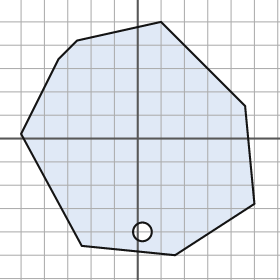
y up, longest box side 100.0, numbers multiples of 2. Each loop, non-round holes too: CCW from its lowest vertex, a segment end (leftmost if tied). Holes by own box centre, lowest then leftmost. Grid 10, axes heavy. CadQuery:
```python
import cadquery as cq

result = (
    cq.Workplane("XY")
    .moveTo(16.0, -50.0)
    .lineTo(50.0, -28.0)
    .lineTo(46.0, 14.0)
    .lineTo(10.0, 50.0)
    .lineTo(-26.0, 42.0)
    .lineTo(-34.0, 34.0)
    .lineTo(-50.0, 2.0)
    .lineTo(-24.0, -46.0)
    .close()
    .moveTo(2.0, -40.0)
    .circle(4.0)
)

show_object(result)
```